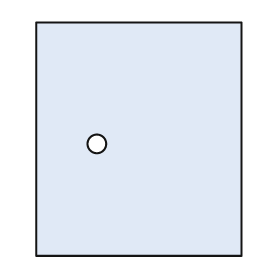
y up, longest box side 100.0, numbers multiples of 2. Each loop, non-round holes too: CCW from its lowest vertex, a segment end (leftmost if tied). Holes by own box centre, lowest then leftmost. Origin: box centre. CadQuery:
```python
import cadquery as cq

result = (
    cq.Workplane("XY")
    .moveTo(-44.0, -50.0)
    .lineTo(44.0, -50.0)
    .lineTo(44.0, 50.0)
    .lineTo(-44.0, 50.0)
    .close()
    .moveTo(-18.0, -2.0)
    .circle(4.0)
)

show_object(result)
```